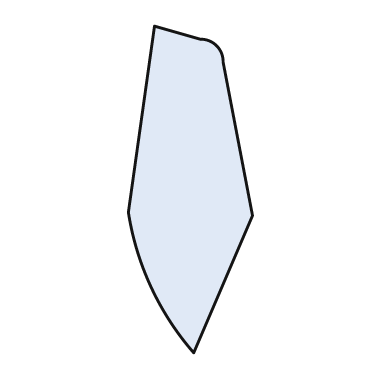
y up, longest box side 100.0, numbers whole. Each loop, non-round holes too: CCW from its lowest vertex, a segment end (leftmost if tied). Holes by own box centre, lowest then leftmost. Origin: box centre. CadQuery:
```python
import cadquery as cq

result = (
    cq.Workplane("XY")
    .moveTo(1.0, -50.0)
    .lineTo(19.0, -8.0)
    .lineTo(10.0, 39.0)
    .threePointArc((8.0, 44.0), (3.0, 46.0))
    .lineTo(-11.0, 50.0)
    .lineTo(-19.0, -7.0)
    .threePointArc((-12.0, -30.0), (1.0, -50.0))
    .close()
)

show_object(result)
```